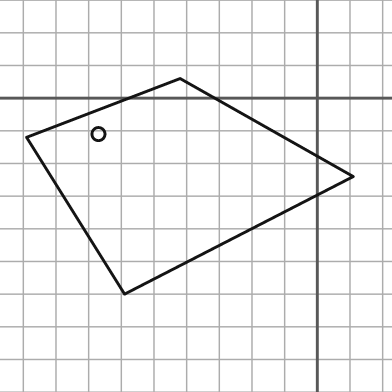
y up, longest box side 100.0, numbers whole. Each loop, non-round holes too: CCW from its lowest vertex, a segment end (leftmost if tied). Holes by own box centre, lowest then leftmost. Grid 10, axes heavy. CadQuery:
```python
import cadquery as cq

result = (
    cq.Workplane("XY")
    .moveTo(-59.0, -60.0)
    .lineTo(11.0, -24.0)
    .lineTo(-42.0, 6.0)
    .lineTo(-89.0, -12.0)
    .close()
    .moveTo(-67.0, -11.0)
    .circle(2.0)
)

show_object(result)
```